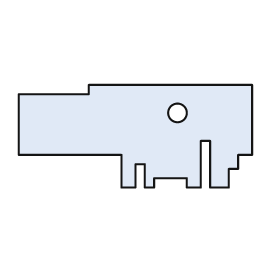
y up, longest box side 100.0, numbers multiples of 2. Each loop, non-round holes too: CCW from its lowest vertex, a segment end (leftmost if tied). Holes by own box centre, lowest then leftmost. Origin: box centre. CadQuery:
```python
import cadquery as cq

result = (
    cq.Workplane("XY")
    .moveTo(-6.0, -22.0)
    .lineTo(0.0, -22.0)
    .lineTo(0.0, -12.0)
    .lineTo(4.0, -12.0)
    .lineTo(4.0, -22.0)
    .lineTo(8.0, -22.0)
    .lineTo(8.0, -18.0)
    .lineTo(22.0, -18.0)
    .lineTo(22.0, -22.0)
    .lineTo(28.0, -22.0)
    .lineTo(28.0, -2.0)
    .lineTo(32.0, -2.0)
    .lineTo(32.0, -22.0)
    .lineTo(40.0, -22.0)
    .lineTo(40.0, -14.0)
    .lineTo(44.0, -14.0)
    .lineTo(44.0, -8.0)
    .lineTo(50.0, -8.0)
    .lineTo(50.0, 22.0)
    .lineTo(-20.0, 22.0)
    .lineTo(-20.0, 18.0)
    .lineTo(-50.0, 18.0)
    .lineTo(-50.0, -8.0)
    .lineTo(-6.0, -8.0)
    .close()
    .moveTo(18.0, 10.0)
    .circle(4.0)
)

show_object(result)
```